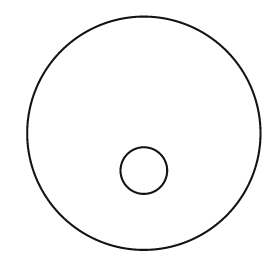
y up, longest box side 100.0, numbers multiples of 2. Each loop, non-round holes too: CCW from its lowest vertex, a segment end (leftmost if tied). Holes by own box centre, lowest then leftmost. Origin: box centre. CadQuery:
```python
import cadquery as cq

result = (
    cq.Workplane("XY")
    .moveTo(0.0, 0.0)
    .circle(50.0)
    .moveTo(0.0, -16.0)
    .circle(10.0)
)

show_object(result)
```